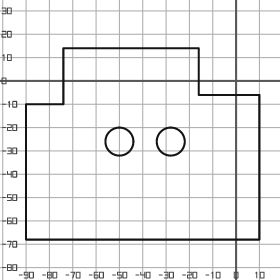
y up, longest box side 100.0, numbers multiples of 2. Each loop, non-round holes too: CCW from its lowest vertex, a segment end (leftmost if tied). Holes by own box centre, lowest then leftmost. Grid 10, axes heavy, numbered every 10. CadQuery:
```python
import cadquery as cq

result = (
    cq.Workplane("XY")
    .moveTo(-90.0, -68.0)
    .lineTo(10.0, -68.0)
    .lineTo(10.0, -6.0)
    .lineTo(-16.0, -6.0)
    .lineTo(-16.0, 14.0)
    .lineTo(-74.0, 14.0)
    .lineTo(-74.0, -10.0)
    .lineTo(-90.0, -10.0)
    .close()
    .moveTo(-50.0, -26.0)
    .circle(6.0)
    .moveTo(-28.0, -26.0)
    .circle(6.0)
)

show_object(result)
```